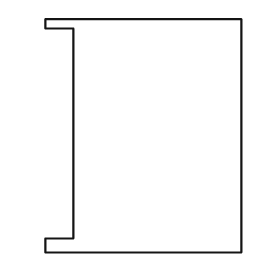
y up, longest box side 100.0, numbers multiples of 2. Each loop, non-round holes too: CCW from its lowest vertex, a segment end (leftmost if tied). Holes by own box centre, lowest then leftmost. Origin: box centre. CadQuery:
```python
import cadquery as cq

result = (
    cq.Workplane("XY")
    .moveTo(-42.0, -50.0)
    .lineTo(42.0, -50.0)
    .lineTo(42.0, 50.0)
    .lineTo(-42.0, 50.0)
    .lineTo(-42.0, 46.0)
    .lineTo(-30.0, 46.0)
    .lineTo(-30.0, -44.0)
    .lineTo(-42.0, -44.0)
    .close()
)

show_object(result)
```